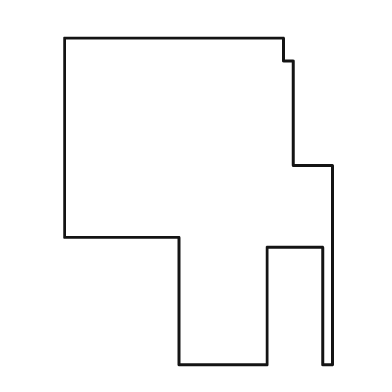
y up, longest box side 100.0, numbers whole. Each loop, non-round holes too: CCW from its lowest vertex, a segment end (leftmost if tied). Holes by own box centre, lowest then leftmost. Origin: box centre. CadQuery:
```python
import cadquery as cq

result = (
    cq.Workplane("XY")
    .moveTo(-6.0, -50.0)
    .lineTo(21.0, -50.0)
    .lineTo(21.0, -14.0)
    .lineTo(38.0, -14.0)
    .lineTo(38.0, -50.0)
    .lineTo(41.0, -50.0)
    .lineTo(41.0, 11.0)
    .lineTo(29.0, 11.0)
    .lineTo(29.0, 43.0)
    .lineTo(26.0, 43.0)
    .lineTo(26.0, 50.0)
    .lineTo(-41.0, 50.0)
    .lineTo(-41.0, -11.0)
    .lineTo(-6.0, -11.0)
    .close()
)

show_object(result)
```